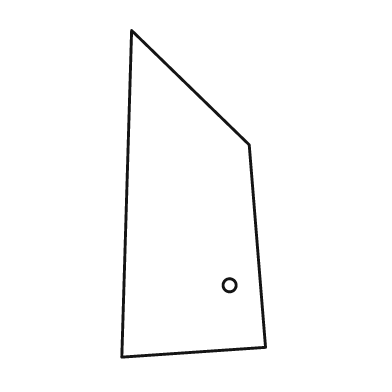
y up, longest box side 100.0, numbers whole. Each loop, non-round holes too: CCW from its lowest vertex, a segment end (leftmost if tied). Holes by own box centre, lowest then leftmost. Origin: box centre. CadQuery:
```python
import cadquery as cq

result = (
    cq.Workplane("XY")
    .moveTo(-22.0, -50.0)
    .lineTo(22.0, -47.0)
    .lineTo(17.0, 15.0)
    .lineTo(-19.0, 50.0)
    .close()
    .moveTo(11.0, -28.0)
    .circle(2.0)
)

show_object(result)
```